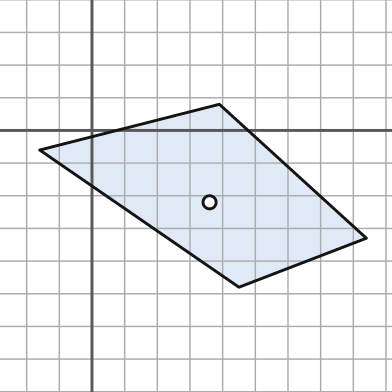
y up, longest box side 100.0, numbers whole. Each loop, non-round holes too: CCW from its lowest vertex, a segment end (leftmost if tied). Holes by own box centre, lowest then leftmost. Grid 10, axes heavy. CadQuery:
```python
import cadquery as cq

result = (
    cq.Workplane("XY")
    .moveTo(45.0, -48.0)
    .lineTo(84.0, -33.0)
    .lineTo(39.0, 8.0)
    .lineTo(-16.0, -6.0)
    .close()
    .moveTo(36.0, -22.0)
    .circle(2.0)
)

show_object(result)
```